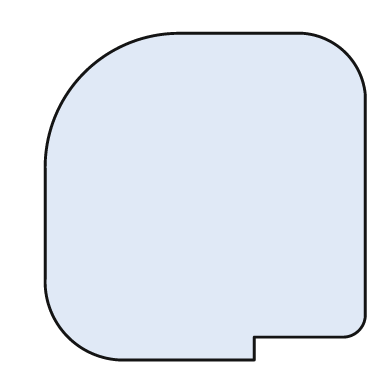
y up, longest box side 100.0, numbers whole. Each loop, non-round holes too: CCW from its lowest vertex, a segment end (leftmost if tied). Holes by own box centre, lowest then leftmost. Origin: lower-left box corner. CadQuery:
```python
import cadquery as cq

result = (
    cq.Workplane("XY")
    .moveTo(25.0, 0.0)
    .lineTo(64.0, 0.0)
    .lineTo(64.0, 7.0)
    .lineTo(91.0, 7.0)
    .threePointArc((96.0, 9.0), (98.0, 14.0))
    .lineTo(98.0, 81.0)
    .threePointArc((92.0, 94.0), (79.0, 100.0))
    .lineTo(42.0, 100.0)
    .threePointArc((12.0, 88.0), (0.0, 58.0))
    .lineTo(0.0, 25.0)
    .threePointArc((7.0, 7.0), (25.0, 0.0))
    .close()
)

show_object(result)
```